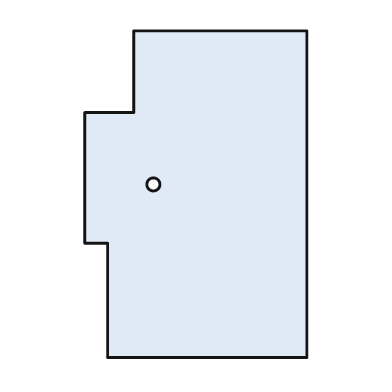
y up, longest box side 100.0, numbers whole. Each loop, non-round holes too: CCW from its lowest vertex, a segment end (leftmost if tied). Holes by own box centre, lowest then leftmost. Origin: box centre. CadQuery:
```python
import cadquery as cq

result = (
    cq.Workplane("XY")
    .moveTo(-27.0, -50.0)
    .lineTo(34.0, -50.0)
    .lineTo(34.0, 50.0)
    .lineTo(-19.0, 50.0)
    .lineTo(-19.0, 25.0)
    .lineTo(-34.0, 25.0)
    .lineTo(-34.0, -15.0)
    .lineTo(-27.0, -15.0)
    .close()
    .moveTo(-13.0, 3.0)
    .circle(2.0)
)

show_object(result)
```